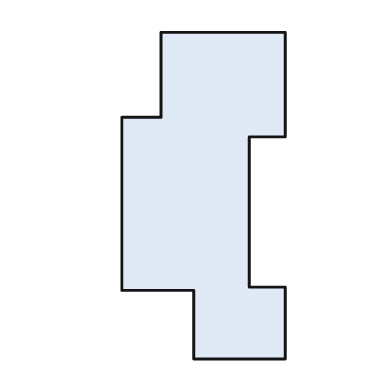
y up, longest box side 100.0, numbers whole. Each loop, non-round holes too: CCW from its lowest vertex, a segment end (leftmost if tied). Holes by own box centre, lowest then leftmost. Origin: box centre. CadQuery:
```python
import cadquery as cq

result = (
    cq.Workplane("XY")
    .moveTo(-3.0, -50.0)
    .lineTo(25.0, -50.0)
    .lineTo(25.0, -28.0)
    .lineTo(14.0, -28.0)
    .lineTo(14.0, 18.0)
    .lineTo(25.0, 18.0)
    .lineTo(25.0, 50.0)
    .lineTo(-13.0, 50.0)
    .lineTo(-13.0, 24.0)
    .lineTo(-25.0, 24.0)
    .lineTo(-25.0, -29.0)
    .lineTo(-3.0, -29.0)
    .close()
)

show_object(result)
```